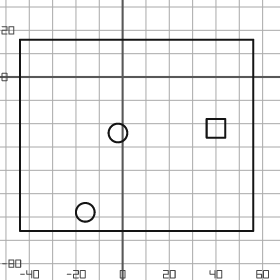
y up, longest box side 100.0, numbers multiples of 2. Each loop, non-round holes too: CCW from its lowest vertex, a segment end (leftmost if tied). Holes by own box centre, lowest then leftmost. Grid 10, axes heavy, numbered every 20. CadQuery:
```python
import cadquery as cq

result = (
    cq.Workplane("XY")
    .moveTo(-44.0, -66.0)
    .lineTo(56.0, -66.0)
    .lineTo(56.0, 16.0)
    .lineTo(-44.0, 16.0)
    .close()
    .moveTo(-16.0, -58.0)
    .circle(4.0)
    .moveTo(-2.0, -24.0)
    .circle(4.0)
    .moveTo(36.0, -26.0)
    .lineTo(44.0, -26.0)
    .lineTo(44.0, -18.0)
    .lineTo(36.0, -18.0)
    .close()
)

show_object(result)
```